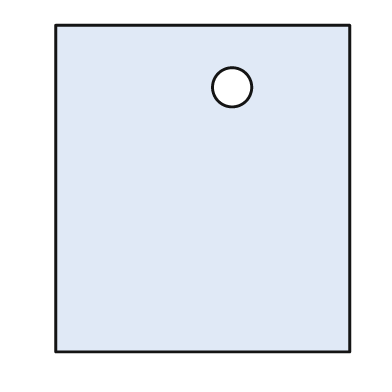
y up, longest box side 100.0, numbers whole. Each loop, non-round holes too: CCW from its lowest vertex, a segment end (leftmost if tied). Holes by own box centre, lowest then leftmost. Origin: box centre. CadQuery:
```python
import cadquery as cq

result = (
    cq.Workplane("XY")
    .moveTo(-45.0, -50.0)
    .lineTo(45.0, -50.0)
    .lineTo(45.0, 50.0)
    .lineTo(-45.0, 50.0)
    .close()
    .moveTo(9.0, 31.0)
    .circle(6.0)
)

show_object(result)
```